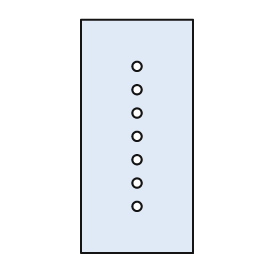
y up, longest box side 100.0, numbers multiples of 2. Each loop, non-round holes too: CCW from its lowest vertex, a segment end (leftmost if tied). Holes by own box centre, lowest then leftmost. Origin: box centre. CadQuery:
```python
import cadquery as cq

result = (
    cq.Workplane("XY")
    .moveTo(-24.0, -50.0)
    .lineTo(24.0, -50.0)
    .lineTo(24.0, 50.0)
    .lineTo(-24.0, 50.0)
    .close()
    .moveTo(0.0, -30.0)
    .circle(2.0)
    .moveTo(0.0, -20.0)
    .circle(2.0)
    .moveTo(0.0, -10.0)
    .circle(2.0)
    .moveTo(0.0, 0.0)
    .circle(2.0)
    .moveTo(0.0, 10.0)
    .circle(2.0)
    .moveTo(0.0, 20.0)
    .circle(2.0)
    .moveTo(0.0, 30.0)
    .circle(2.0)
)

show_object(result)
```